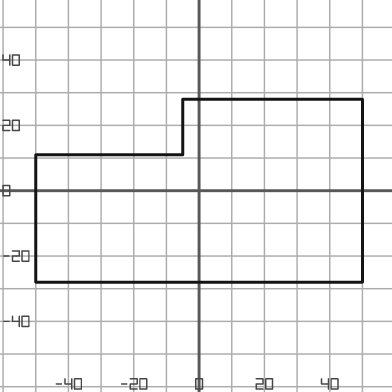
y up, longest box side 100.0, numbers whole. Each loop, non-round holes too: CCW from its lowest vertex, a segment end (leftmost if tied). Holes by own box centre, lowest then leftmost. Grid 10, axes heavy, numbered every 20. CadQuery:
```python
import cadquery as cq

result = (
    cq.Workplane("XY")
    .moveTo(-50.0, -28.0)
    .lineTo(50.0, -28.0)
    .lineTo(50.0, 28.0)
    .lineTo(-5.0, 28.0)
    .lineTo(-5.0, 11.0)
    .lineTo(-50.0, 11.0)
    .close()
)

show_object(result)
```